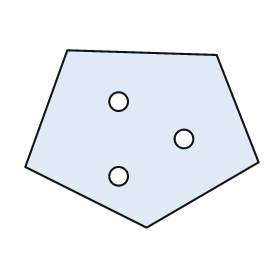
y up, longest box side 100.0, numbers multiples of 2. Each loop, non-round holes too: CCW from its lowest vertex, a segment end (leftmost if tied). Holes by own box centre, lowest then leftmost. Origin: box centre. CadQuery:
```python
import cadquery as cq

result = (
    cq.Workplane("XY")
    .moveTo(2.0, -38.0)
    .lineTo(50.0, -10.0)
    .lineTo(32.0, 36.0)
    .lineTo(-32.0, 38.0)
    .lineTo(-50.0, -12.0)
    .close()
    .moveTo(-10.0, -16.0)
    .circle(4.0)
    .moveTo(18.0, 0.0)
    .circle(4.0)
    .moveTo(-10.0, 16.0)
    .circle(4.0)
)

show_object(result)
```